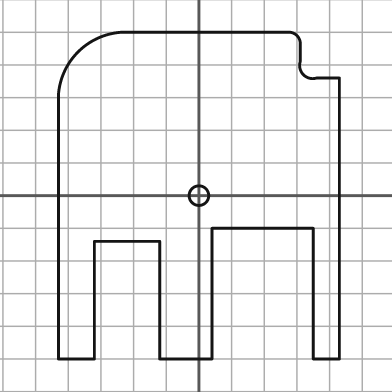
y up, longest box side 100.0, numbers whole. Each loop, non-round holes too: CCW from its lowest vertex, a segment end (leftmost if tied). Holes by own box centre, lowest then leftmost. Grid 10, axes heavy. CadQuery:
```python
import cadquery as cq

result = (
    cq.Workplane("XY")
    .moveTo(-43.0, -50.0)
    .lineTo(-32.0, -50.0)
    .lineTo(-32.0, -14.0)
    .lineTo(-12.0, -14.0)
    .lineTo(-12.0, -50.0)
    .lineTo(4.0, -50.0)
    .lineTo(4.0, -10.0)
    .lineTo(35.0, -10.0)
    .lineTo(35.0, -50.0)
    .lineTo(43.0, -50.0)
    .lineTo(43.0, 36.0)
    .lineTo(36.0, 36.0)
    .threePointArc((32.0, 37.0), (31.0, 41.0))
    .lineTo(31.0, 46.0)
    .threePointArc((30.0, 49.0), (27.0, 50.0))
    .lineTo(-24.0, 50.0)
    .threePointArc((-37.0, 44.0), (-43.0, 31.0))
    .close()
    .moveTo(0.0, 0.0)
    .circle(3.0)
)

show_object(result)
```